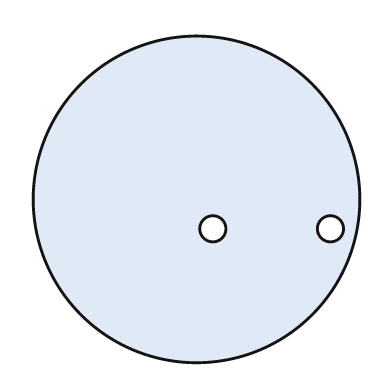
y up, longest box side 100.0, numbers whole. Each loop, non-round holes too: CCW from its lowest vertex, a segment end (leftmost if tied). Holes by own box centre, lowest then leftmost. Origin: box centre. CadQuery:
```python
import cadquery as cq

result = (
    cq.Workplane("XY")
    .moveTo(0.0, 0.0)
    .circle(50.0)
    .moveTo(5.0, -9.0)
    .circle(4.0)
    .moveTo(41.0, -9.0)
    .circle(4.0)
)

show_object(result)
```